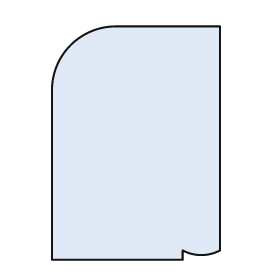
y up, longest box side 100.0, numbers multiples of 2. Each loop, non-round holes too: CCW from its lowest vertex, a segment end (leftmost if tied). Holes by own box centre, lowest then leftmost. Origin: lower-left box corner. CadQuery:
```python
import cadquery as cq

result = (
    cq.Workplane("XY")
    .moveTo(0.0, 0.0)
    .lineTo(56.0, 0.0)
    .lineTo(56.0, 4.0)
    .threePointArc((64.0, 2.0), (72.0, 4.0))
    .lineTo(72.0, 100.0)
    .lineTo(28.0, 100.0)
    .threePointArc((8.0, 92.0), (0.0, 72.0))
    .close()
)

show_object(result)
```